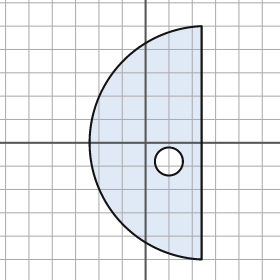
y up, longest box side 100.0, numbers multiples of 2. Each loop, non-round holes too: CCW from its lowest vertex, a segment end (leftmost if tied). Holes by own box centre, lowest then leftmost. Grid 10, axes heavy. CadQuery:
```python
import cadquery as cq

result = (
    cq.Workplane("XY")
    .moveTo(24.0, -50.0)
    .lineTo(24.0, 50.0)
    .threePointArc((-24.0, 0.0), (24.0, -50.0))
    .close()
    .moveTo(10.0, -8.0)
    .circle(6.0)
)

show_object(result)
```